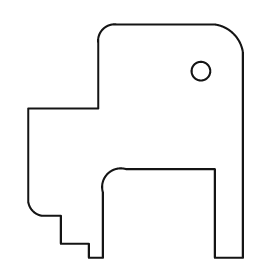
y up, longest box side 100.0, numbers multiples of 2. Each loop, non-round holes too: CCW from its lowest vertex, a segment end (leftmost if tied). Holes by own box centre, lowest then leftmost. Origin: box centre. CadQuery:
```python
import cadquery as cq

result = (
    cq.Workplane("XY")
    .moveTo(-20.0, -50.0)
    .lineTo(-14.0, -50.0)
    .lineTo(-14.0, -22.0)
    .threePointArc((-12.0, -14.0), (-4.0, -12.0))
    .lineTo(34.0, -12.0)
    .lineTo(34.0, -50.0)
    .lineTo(46.0, -50.0)
    .lineTo(46.0, 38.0)
    .threePointArc((42.0, 46.0), (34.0, 50.0))
    .lineTo(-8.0, 50.0)
    .threePointArc((-14.0, 48.0), (-16.0, 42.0))
    .lineTo(-16.0, 14.0)
    .lineTo(-46.0, 14.0)
    .lineTo(-46.0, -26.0)
    .threePointArc((-44.0, -30.0), (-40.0, -32.0))
    .lineTo(-32.0, -32.0)
    .lineTo(-32.0, -44.0)
    .lineTo(-20.0, -44.0)
    .close()
    .moveTo(28.0, 30.0)
    .circle(4.0)
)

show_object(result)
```